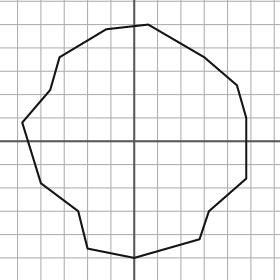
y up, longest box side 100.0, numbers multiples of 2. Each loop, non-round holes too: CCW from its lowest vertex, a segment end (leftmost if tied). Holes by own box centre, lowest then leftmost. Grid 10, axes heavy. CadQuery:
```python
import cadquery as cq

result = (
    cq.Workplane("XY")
    .moveTo(0.0, -50.0)
    .lineTo(28.0, -42.0)
    .lineTo(32.0, -30.0)
    .lineTo(48.0, -16.0)
    .lineTo(48.0, 10.0)
    .lineTo(44.0, 24.0)
    .lineTo(30.0, 36.0)
    .lineTo(6.0, 50.0)
    .lineTo(-12.0, 48.0)
    .lineTo(-32.0, 36.0)
    .lineTo(-36.0, 22.0)
    .lineTo(-48.0, 8.0)
    .lineTo(-40.0, -18.0)
    .lineTo(-24.0, -30.0)
    .lineTo(-20.0, -46.0)
    .close()
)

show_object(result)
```